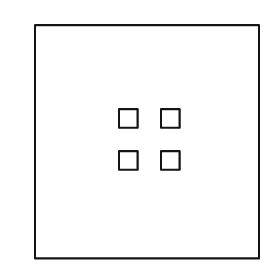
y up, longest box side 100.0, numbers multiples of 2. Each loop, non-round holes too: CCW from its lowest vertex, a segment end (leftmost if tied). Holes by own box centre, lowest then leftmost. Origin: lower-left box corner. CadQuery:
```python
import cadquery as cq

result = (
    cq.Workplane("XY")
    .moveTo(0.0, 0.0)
    .lineTo(96.0, 0.0)
    .lineTo(96.0, 100.0)
    .lineTo(0.0, 100.0)
    .close()
    .moveTo(36.0, 38.0)
    .lineTo(44.0, 38.0)
    .lineTo(44.0, 46.0)
    .lineTo(36.0, 46.0)
    .close()
    .moveTo(54.0, 38.0)
    .lineTo(62.0, 38.0)
    .lineTo(62.0, 46.0)
    .lineTo(54.0, 46.0)
    .close()
    .moveTo(36.0, 56.0)
    .lineTo(44.0, 56.0)
    .lineTo(44.0, 64.0)
    .lineTo(36.0, 64.0)
    .close()
    .moveTo(54.0, 56.0)
    .lineTo(62.0, 56.0)
    .lineTo(62.0, 64.0)
    .lineTo(54.0, 64.0)
    .close()
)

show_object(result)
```